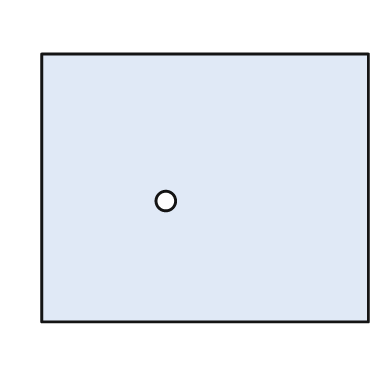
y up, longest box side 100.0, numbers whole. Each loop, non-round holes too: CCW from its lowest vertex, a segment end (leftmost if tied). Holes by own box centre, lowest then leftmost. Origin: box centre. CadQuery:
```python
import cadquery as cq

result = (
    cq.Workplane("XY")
    .moveTo(-50.0, -41.0)
    .lineTo(50.0, -41.0)
    .lineTo(50.0, 41.0)
    .lineTo(-50.0, 41.0)
    .close()
    .moveTo(-12.0, -4.0)
    .circle(3.0)
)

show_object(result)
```